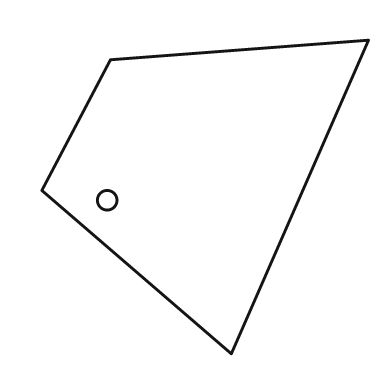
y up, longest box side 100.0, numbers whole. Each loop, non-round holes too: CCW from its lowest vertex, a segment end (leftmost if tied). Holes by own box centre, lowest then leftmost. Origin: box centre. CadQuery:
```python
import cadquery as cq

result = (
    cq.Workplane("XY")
    .moveTo(8.0, -48.0)
    .lineTo(50.0, 48.0)
    .lineTo(-29.0, 42.0)
    .lineTo(-50.0, 2.0)
    .close()
    .moveTo(-30.0, -1.0)
    .circle(3.0)
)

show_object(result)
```